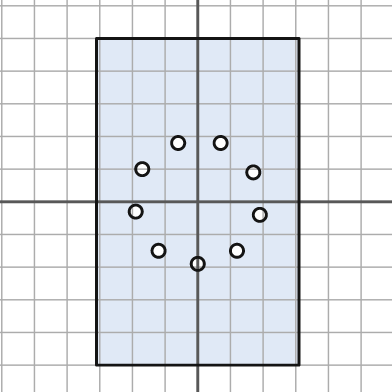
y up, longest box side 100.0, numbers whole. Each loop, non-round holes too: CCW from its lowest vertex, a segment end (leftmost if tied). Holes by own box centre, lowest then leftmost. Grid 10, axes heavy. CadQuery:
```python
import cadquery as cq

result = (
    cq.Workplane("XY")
    .moveTo(-31.0, -50.0)
    .lineTo(31.0, -50.0)
    .lineTo(31.0, 50.0)
    .lineTo(-31.0, 50.0)
    .close()
    .moveTo(0.0, -19.0)
    .circle(2.0)
    .moveTo(-12.0, -15.0)
    .circle(2.0)
    .moveTo(12.0, -15.0)
    .circle(2.0)
    .moveTo(19.0, -4.0)
    .circle(2.0)
    .moveTo(-19.0, -3.0)
    .circle(2.0)
    .moveTo(17.0, 9.0)
    .circle(2.0)
    .moveTo(-17.0, 10.0)
    .circle(2.0)
    .moveTo(-6.0, 18.0)
    .circle(2.0)
    .moveTo(7.0, 18.0)
    .circle(2.0)
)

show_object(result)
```